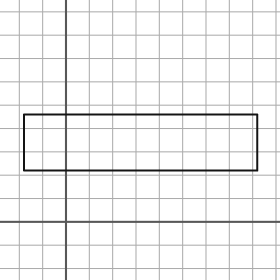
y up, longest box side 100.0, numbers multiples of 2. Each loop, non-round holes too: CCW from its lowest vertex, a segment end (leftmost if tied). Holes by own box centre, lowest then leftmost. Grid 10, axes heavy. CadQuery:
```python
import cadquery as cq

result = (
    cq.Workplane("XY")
    .moveTo(-18.0, 22.0)
    .lineTo(82.0, 22.0)
    .lineTo(82.0, 46.0)
    .lineTo(-18.0, 46.0)
    .close()
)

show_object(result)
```